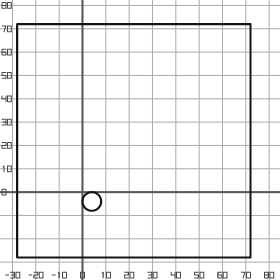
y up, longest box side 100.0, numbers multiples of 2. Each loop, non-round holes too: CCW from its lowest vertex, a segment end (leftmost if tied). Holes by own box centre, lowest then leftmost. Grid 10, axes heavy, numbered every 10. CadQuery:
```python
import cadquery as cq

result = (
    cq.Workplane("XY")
    .moveTo(-28.0, -28.0)
    .lineTo(72.0, -28.0)
    .lineTo(72.0, 72.0)
    .lineTo(-28.0, 72.0)
    .close()
    .moveTo(4.0, -4.0)
    .circle(4.0)
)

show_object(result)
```